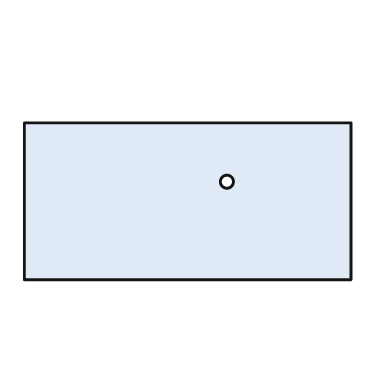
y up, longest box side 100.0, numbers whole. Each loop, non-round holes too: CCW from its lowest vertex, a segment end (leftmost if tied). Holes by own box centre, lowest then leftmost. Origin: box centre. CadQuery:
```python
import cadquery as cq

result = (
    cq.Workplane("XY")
    .moveTo(-50.0, -24.0)
    .lineTo(50.0, -24.0)
    .lineTo(50.0, 24.0)
    .lineTo(-50.0, 24.0)
    .close()
    .moveTo(12.0, 6.0)
    .circle(2.0)
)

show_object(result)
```